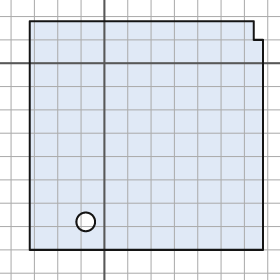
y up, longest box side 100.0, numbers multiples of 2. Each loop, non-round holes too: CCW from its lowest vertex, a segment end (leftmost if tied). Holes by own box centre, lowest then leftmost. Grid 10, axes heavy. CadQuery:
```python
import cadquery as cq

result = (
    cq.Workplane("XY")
    .moveTo(-32.0, -80.0)
    .lineTo(68.0, -80.0)
    .lineTo(68.0, 10.0)
    .lineTo(64.0, 10.0)
    .lineTo(64.0, 18.0)
    .lineTo(-32.0, 18.0)
    .close()
    .moveTo(-8.0, -68.0)
    .circle(4.0)
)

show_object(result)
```